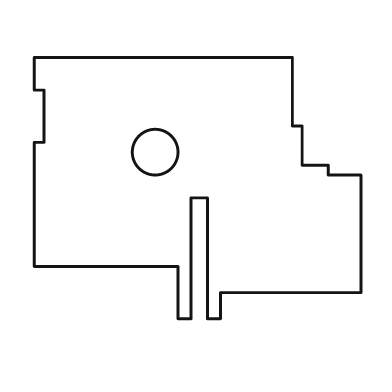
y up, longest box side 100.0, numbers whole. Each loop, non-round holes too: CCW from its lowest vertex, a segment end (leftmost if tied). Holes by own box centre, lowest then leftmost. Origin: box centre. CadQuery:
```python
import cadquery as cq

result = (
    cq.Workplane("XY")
    .moveTo(-6.0, -40.0)
    .lineTo(-2.0, -40.0)
    .lineTo(-2.0, -3.0)
    .lineTo(3.0, -3.0)
    .lineTo(3.0, -40.0)
    .lineTo(7.0, -40.0)
    .lineTo(7.0, -32.0)
    .lineTo(50.0, -32.0)
    .lineTo(50.0, 4.0)
    .lineTo(40.0, 4.0)
    .lineTo(40.0, 7.0)
    .lineTo(32.0, 7.0)
    .lineTo(32.0, 19.0)
    .lineTo(29.0, 19.0)
    .lineTo(29.0, 40.0)
    .lineTo(-50.0, 40.0)
    .lineTo(-50.0, 30.0)
    .lineTo(-47.0, 30.0)
    .lineTo(-47.0, 14.0)
    .lineTo(-50.0, 14.0)
    .lineTo(-50.0, -24.0)
    .lineTo(-6.0, -24.0)
    .close()
    .moveTo(-13.0, 11.0)
    .circle(7.0)
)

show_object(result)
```